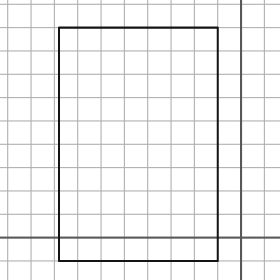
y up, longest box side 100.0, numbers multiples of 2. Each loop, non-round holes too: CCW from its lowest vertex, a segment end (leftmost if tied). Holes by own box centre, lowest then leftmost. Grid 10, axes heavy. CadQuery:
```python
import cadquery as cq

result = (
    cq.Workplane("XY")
    .moveTo(-78.0, -10.0)
    .lineTo(-10.0, -10.0)
    .lineTo(-10.0, 90.0)
    .lineTo(-78.0, 90.0)
    .close()
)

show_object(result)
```